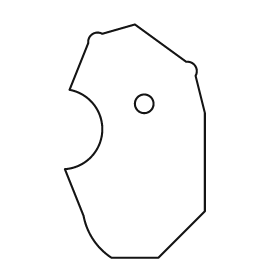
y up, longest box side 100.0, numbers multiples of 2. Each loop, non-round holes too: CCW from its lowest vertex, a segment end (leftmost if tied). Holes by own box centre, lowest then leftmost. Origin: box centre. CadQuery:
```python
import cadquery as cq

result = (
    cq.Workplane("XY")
    .moveTo(-10.0, -50.0)
    .lineTo(10.0, -50.0)
    .lineTo(30.0, -30.0)
    .lineTo(30.0, 12.0)
    .lineTo(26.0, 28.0)
    .threePointArc((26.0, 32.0), (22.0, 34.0))
    .lineTo(0.0, 50.0)
    .lineTo(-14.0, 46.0)
    .threePointArc((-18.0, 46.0), (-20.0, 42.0))
    .lineTo(-28.0, 22.0)
    .threePointArc((-14.0, 4.0), (-30.0, -12.0))
    .lineTo(-22.0, -32.0)
    .threePointArc((-18.0, -42.0), (-10.0, -50.0))
    .close()
    .moveTo(4.0, 16.0)
    .circle(4.0)
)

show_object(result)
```